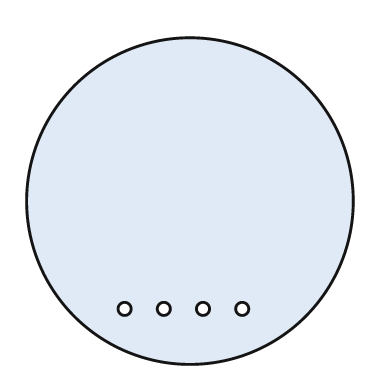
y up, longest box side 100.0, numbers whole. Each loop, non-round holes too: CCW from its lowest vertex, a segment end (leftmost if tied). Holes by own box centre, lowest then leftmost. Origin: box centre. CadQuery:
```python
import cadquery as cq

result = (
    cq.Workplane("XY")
    .moveTo(0.0, 0.0)
    .circle(50.0)
    .moveTo(-20.0, -33.0)
    .circle(2.0)
    .moveTo(-8.0, -33.0)
    .circle(2.0)
    .moveTo(4.0, -33.0)
    .circle(2.0)
    .moveTo(16.0, -33.0)
    .circle(2.0)
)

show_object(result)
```